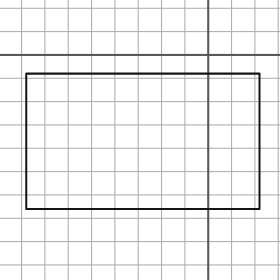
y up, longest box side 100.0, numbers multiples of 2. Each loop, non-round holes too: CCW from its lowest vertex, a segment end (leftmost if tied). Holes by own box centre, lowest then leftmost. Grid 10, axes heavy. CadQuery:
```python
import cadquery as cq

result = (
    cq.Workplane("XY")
    .moveTo(-78.0, -66.0)
    .lineTo(22.0, -66.0)
    .lineTo(22.0, -8.0)
    .lineTo(-78.0, -8.0)
    .close()
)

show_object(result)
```